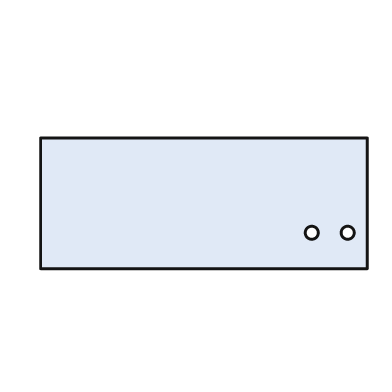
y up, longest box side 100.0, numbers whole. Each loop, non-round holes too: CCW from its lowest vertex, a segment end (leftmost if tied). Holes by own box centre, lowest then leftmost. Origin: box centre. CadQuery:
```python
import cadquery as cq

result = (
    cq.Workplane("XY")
    .moveTo(-50.0, -20.0)
    .lineTo(50.0, -20.0)
    .lineTo(50.0, 20.0)
    .lineTo(-50.0, 20.0)
    .close()
    .moveTo(33.0, -9.0)
    .circle(2.0)
    .moveTo(44.0, -9.0)
    .circle(2.0)
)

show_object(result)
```